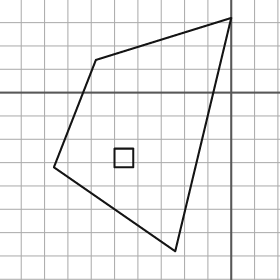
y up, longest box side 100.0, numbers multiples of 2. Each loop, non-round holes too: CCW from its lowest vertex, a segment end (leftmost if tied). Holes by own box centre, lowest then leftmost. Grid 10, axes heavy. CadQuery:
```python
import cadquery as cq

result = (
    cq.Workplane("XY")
    .moveTo(-24.0, -68.0)
    .lineTo(0.0, 32.0)
    .lineTo(-58.0, 14.0)
    .lineTo(-76.0, -32.0)
    .close()
    .moveTo(-50.0, -32.0)
    .lineTo(-42.0, -32.0)
    .lineTo(-42.0, -24.0)
    .lineTo(-50.0, -24.0)
    .close()
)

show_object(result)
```